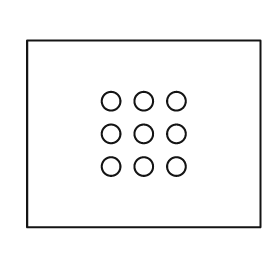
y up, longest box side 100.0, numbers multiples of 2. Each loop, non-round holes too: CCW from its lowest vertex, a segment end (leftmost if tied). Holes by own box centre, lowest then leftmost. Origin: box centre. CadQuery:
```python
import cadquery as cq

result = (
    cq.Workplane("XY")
    .moveTo(-50.0, -40.0)
    .lineTo(50.0, -40.0)
    .lineTo(50.0, 40.0)
    .lineTo(-50.0, 40.0)
    .close()
    .moveTo(-14.0, -14.0)
    .circle(4.0)
    .moveTo(0.0, -14.0)
    .circle(4.0)
    .moveTo(14.0, -14.0)
    .circle(4.0)
    .moveTo(-14.0, 0.0)
    .circle(4.0)
    .moveTo(0.0, 0.0)
    .circle(4.0)
    .moveTo(14.0, 0.0)
    .circle(4.0)
    .moveTo(-14.0, 14.0)
    .circle(4.0)
    .moveTo(0.0, 14.0)
    .circle(4.0)
    .moveTo(14.0, 14.0)
    .circle(4.0)
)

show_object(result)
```